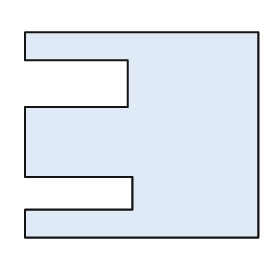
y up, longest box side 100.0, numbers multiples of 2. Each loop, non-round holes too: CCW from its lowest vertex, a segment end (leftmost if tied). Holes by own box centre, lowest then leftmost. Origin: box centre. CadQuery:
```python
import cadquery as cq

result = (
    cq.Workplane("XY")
    .moveTo(-50.0, -44.0)
    .lineTo(50.0, -44.0)
    .lineTo(50.0, 44.0)
    .lineTo(-50.0, 44.0)
    .lineTo(-50.0, 32.0)
    .lineTo(-6.0, 32.0)
    .lineTo(-6.0, 12.0)
    .lineTo(-50.0, 12.0)
    .lineTo(-50.0, -18.0)
    .lineTo(-4.0, -18.0)
    .lineTo(-4.0, -32.0)
    .lineTo(-50.0, -32.0)
    .close()
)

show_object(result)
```